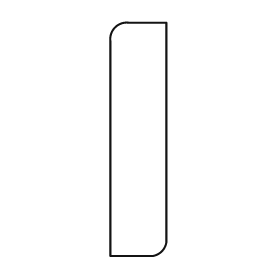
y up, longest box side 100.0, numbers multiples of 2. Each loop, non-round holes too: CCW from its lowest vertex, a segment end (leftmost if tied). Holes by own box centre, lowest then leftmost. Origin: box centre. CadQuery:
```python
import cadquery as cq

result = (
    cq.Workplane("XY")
    .moveTo(-12.0, -50.0)
    .lineTo(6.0, -50.0)
    .threePointArc((10.0, -48.0), (12.0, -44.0))
    .lineTo(12.0, 50.0)
    .lineTo(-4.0, 50.0)
    .threePointArc((-10.0, 48.0), (-12.0, 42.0))
    .close()
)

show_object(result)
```